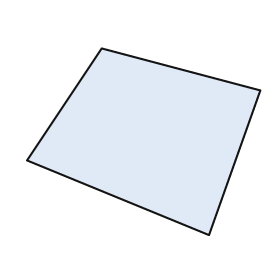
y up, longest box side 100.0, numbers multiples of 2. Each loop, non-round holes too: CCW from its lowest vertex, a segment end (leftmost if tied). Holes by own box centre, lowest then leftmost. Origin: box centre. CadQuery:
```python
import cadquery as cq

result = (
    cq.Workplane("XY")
    .moveTo(28.0, -40.0)
    .lineTo(50.0, 22.0)
    .lineTo(-18.0, 40.0)
    .lineTo(-50.0, -8.0)
    .close()
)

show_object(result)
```